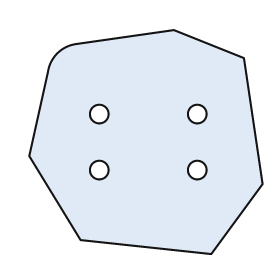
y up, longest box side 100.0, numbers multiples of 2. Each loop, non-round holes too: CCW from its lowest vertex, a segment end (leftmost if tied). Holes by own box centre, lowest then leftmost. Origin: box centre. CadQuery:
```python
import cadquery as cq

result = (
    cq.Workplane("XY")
    .moveTo(28.0, -48.0)
    .lineTo(50.0, -18.0)
    .lineTo(42.0, 36.0)
    .lineTo(12.0, 48.0)
    .lineTo(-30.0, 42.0)
    .threePointArc((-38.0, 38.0), (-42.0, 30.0))
    .lineTo(-50.0, -6.0)
    .lineTo(-28.0, -42.0)
    .close()
    .moveTo(-20.0, -12.0)
    .circle(4.0)
    .moveTo(22.0, -12.0)
    .circle(4.0)
    .moveTo(-20.0, 12.0)
    .circle(4.0)
    .moveTo(22.0, 12.0)
    .circle(4.0)
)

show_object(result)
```